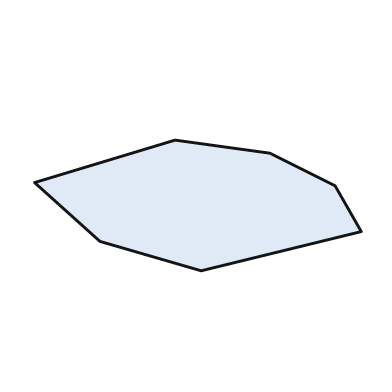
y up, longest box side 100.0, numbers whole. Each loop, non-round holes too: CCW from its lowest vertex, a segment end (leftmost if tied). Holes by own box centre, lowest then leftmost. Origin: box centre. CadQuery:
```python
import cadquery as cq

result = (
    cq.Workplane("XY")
    .moveTo(1.0, -20.0)
    .lineTo(50.0, -8.0)
    .lineTo(42.0, 6.0)
    .lineTo(22.0, 16.0)
    .lineTo(-7.0, 20.0)
    .lineTo(-50.0, 7.0)
    .lineTo(-30.0, -11.0)
    .close()
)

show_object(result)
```